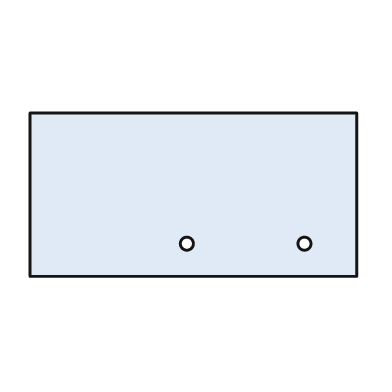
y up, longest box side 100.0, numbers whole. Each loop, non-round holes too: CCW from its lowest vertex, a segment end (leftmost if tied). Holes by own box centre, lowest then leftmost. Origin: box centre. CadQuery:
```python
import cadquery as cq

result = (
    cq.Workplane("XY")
    .moveTo(-50.0, -25.0)
    .lineTo(50.0, -25.0)
    .lineTo(50.0, 25.0)
    .lineTo(-50.0, 25.0)
    .close()
    .moveTo(-2.0, -15.0)
    .circle(2.0)
    .moveTo(34.0, -15.0)
    .circle(2.0)
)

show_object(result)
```